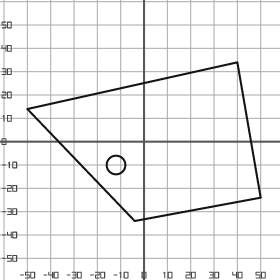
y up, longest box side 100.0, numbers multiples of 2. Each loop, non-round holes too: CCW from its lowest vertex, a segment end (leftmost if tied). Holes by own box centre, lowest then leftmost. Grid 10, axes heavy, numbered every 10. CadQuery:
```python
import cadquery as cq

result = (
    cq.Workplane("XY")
    .moveTo(-4.0, -34.0)
    .lineTo(50.0, -24.0)
    .lineTo(40.0, 34.0)
    .lineTo(-50.0, 14.0)
    .close()
    .moveTo(-12.0, -10.0)
    .circle(4.0)
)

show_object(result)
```